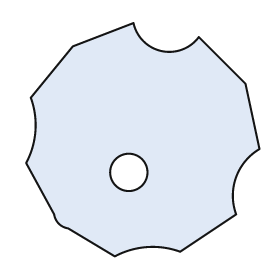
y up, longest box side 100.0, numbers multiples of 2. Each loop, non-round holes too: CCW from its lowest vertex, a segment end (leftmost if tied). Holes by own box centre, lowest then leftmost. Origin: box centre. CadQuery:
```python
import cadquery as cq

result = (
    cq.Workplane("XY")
    .moveTo(-12.0, -50.0)
    .threePointArc((2.0, -46.0), (16.0, -48.0))
    .lineTo(40.0, -32.0)
    .threePointArc((40.0, -16.0), (50.0, -4.0))
    .lineTo(44.0, 24.0)
    .lineTo(24.0, 44.0)
    .threePointArc((8.0, 38.0), (-4.0, 50.0))
    .lineTo(-30.0, 40.0)
    .lineTo(-48.0, 18.0)
    .threePointArc((-46.0, 4.0), (-50.0, -10.0))
    .lineTo(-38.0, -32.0)
    .threePointArc((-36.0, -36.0), (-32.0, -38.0))
    .close()
    .moveTo(-6.0, -14.0)
    .circle(8.0)
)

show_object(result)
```